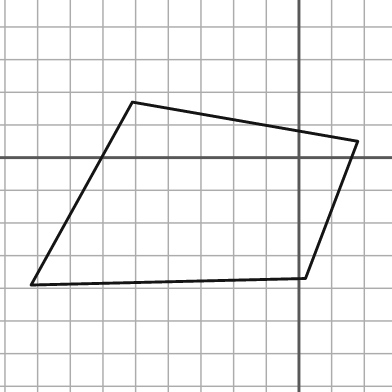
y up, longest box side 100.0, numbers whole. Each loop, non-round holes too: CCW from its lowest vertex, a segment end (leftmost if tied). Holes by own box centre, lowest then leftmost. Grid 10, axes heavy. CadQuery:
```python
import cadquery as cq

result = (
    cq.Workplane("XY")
    .moveTo(-82.0, -39.0)
    .lineTo(2.0, -37.0)
    .lineTo(18.0, 5.0)
    .lineTo(-51.0, 17.0)
    .close()
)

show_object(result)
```